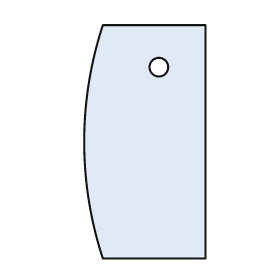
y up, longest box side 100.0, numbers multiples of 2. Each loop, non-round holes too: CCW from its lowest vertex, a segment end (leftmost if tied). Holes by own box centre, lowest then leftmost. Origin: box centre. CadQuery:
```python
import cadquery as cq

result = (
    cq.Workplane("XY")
    .moveTo(-18.0, -50.0)
    .lineTo(26.0, -50.0)
    .lineTo(26.0, 50.0)
    .lineTo(-18.0, 50.0)
    .threePointArc((-26.0, 0.0), (-18.0, -50.0))
    .close()
    .moveTo(6.0, 32.0)
    .circle(4.0)
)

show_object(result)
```